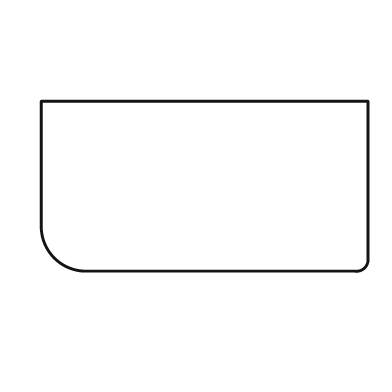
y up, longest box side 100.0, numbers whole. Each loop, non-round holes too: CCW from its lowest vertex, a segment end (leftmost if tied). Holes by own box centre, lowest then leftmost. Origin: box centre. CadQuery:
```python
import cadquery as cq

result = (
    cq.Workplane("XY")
    .moveTo(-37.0, -26.0)
    .lineTo(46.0, -26.0)
    .threePointArc((49.0, -25.0), (50.0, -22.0))
    .lineTo(50.0, 26.0)
    .lineTo(-50.0, 26.0)
    .lineTo(-50.0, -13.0)
    .threePointArc((-46.0, -22.0), (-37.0, -26.0))
    .close()
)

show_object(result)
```